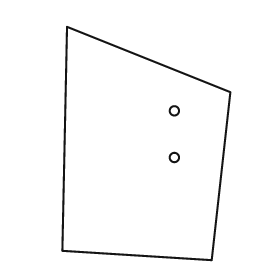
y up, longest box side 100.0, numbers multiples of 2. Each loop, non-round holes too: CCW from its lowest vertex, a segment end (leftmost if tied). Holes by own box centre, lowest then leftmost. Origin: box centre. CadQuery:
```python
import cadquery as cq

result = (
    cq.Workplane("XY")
    .moveTo(28.0, -50.0)
    .lineTo(36.0, 22.0)
    .lineTo(-34.0, 50.0)
    .lineTo(-36.0, -46.0)
    .close()
    .moveTo(12.0, -6.0)
    .circle(2.0)
    .moveTo(12.0, 14.0)
    .circle(2.0)
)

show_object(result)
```